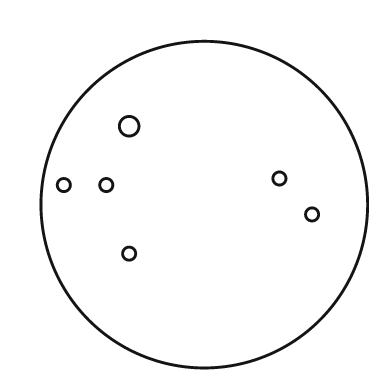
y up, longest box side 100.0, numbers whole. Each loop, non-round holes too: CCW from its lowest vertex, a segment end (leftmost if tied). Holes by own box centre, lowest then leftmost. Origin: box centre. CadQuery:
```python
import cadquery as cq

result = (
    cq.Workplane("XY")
    .moveTo(0.0, 0.0)
    .circle(50.0)
    .moveTo(-23.0, -15.0)
    .circle(2.0)
    .moveTo(33.0, -3.0)
    .circle(2.0)
    .moveTo(-43.0, 6.0)
    .circle(2.0)
    .moveTo(-30.0, 6.0)
    .circle(2.0)
    .moveTo(23.0, 8.0)
    .circle(2.0)
    .moveTo(-23.0, 24.0)
    .circle(3.0)
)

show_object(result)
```